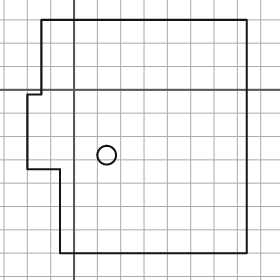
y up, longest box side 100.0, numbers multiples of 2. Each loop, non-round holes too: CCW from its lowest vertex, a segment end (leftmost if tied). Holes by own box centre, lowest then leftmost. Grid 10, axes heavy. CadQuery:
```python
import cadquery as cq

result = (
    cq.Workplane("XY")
    .moveTo(-6.0, -70.0)
    .lineTo(74.0, -70.0)
    .lineTo(74.0, 30.0)
    .lineTo(-14.0, 30.0)
    .lineTo(-14.0, -2.0)
    .lineTo(-20.0, -2.0)
    .lineTo(-20.0, -34.0)
    .lineTo(-6.0, -34.0)
    .close()
    .moveTo(14.0, -28.0)
    .circle(4.0)
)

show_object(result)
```